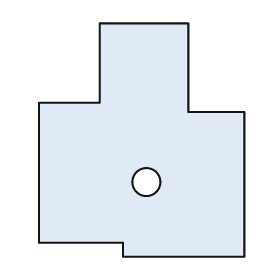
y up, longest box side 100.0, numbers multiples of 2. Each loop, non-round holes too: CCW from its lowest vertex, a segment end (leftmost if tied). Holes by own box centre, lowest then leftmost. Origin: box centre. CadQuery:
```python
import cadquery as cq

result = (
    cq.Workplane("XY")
    .moveTo(-8.0, -50.0)
    .lineTo(44.0, -50.0)
    .lineTo(44.0, 12.0)
    .lineTo(20.0, 12.0)
    .lineTo(20.0, 50.0)
    .lineTo(-18.0, 50.0)
    .lineTo(-18.0, 16.0)
    .lineTo(-44.0, 16.0)
    .lineTo(-44.0, -44.0)
    .lineTo(-8.0, -44.0)
    .close()
    .moveTo(2.0, -18.0)
    .circle(6.0)
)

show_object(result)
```